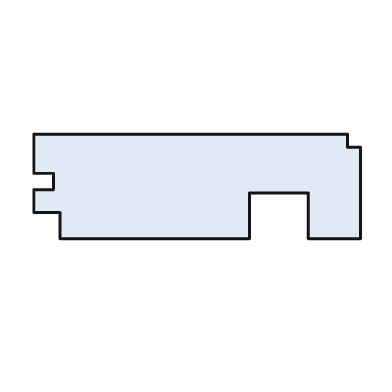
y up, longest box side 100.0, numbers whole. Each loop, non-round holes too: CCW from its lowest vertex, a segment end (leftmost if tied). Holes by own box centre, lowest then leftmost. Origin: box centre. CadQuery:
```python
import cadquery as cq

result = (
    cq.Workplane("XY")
    .moveTo(-42.0, -16.0)
    .lineTo(16.0, -16.0)
    .lineTo(16.0, -2.0)
    .lineTo(34.0, -2.0)
    .lineTo(34.0, -16.0)
    .lineTo(50.0, -16.0)
    .lineTo(50.0, 12.0)
    .lineTo(46.0, 12.0)
    .lineTo(46.0, 16.0)
    .lineTo(-50.0, 16.0)
    .lineTo(-50.0, 4.0)
    .lineTo(-44.0, 4.0)
    .lineTo(-44.0, -1.0)
    .lineTo(-50.0, -1.0)
    .lineTo(-50.0, -8.0)
    .lineTo(-42.0, -8.0)
    .close()
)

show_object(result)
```